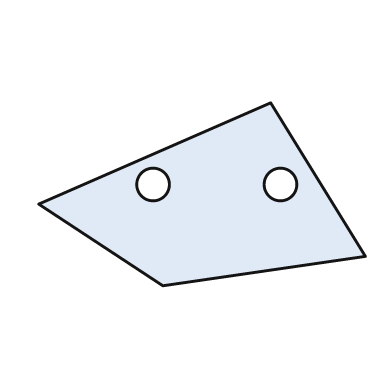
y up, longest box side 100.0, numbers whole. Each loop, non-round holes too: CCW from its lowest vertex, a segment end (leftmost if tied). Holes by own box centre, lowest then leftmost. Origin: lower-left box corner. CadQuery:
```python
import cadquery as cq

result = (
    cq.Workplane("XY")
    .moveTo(38.0, 0.0)
    .lineTo(100.0, 9.0)
    .lineTo(71.0, 56.0)
    .lineTo(0.0, 25.0)
    .close()
    .moveTo(35.0, 31.0)
    .circle(5.0)
    .moveTo(74.0, 31.0)
    .circle(5.0)
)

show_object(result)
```